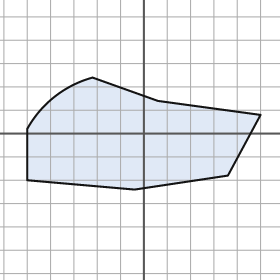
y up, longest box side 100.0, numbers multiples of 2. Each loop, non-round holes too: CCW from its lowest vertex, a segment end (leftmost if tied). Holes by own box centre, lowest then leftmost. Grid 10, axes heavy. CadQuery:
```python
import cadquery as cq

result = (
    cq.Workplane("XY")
    .moveTo(-4.0, -24.0)
    .lineTo(36.0, -18.0)
    .lineTo(50.0, 8.0)
    .lineTo(6.0, 14.0)
    .lineTo(-22.0, 24.0)
    .threePointArc((-38.0, 16.0), (-50.0, 2.0))
    .lineTo(-50.0, -20.0)
    .close()
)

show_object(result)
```